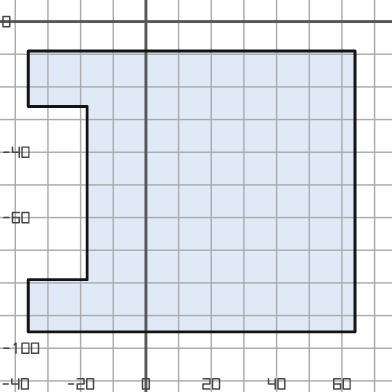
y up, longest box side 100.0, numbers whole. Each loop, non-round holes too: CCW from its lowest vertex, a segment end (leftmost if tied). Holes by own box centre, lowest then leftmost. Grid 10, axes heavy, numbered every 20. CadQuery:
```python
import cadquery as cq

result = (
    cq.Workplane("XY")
    .moveTo(-36.0, -95.0)
    .lineTo(64.0, -95.0)
    .lineTo(64.0, -9.0)
    .lineTo(-36.0, -9.0)
    .lineTo(-36.0, -26.0)
    .lineTo(-18.0, -26.0)
    .lineTo(-18.0, -79.0)
    .lineTo(-36.0, -79.0)
    .close()
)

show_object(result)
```